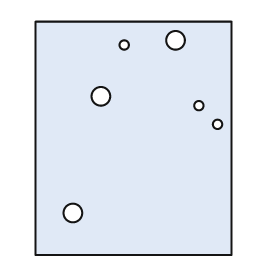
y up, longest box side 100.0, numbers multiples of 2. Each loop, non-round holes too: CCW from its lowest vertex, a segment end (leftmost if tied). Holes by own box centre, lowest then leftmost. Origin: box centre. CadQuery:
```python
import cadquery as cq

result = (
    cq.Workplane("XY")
    .moveTo(-42.0, -50.0)
    .lineTo(42.0, -50.0)
    .lineTo(42.0, 50.0)
    .lineTo(-42.0, 50.0)
    .close()
    .moveTo(-26.0, -32.0)
    .circle(4.0)
    .moveTo(36.0, 6.0)
    .circle(2.0)
    .moveTo(28.0, 14.0)
    .circle(2.0)
    .moveTo(-14.0, 18.0)
    .circle(4.0)
    .moveTo(-4.0, 40.0)
    .circle(2.0)
    .moveTo(18.0, 42.0)
    .circle(4.0)
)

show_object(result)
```